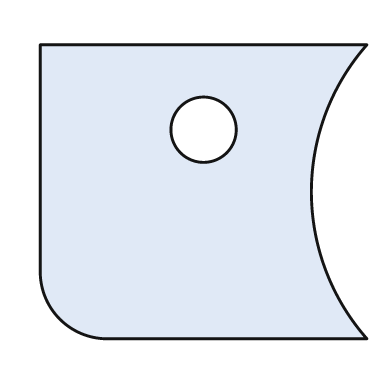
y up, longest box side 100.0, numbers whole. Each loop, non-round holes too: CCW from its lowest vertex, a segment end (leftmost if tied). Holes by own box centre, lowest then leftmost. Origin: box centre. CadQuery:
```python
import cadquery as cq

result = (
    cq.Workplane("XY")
    .moveTo(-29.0, -45.0)
    .lineTo(50.0, -45.0)
    .threePointArc((33.0, 0.0), (50.0, 45.0))
    .lineTo(-50.0, 45.0)
    .lineTo(-50.0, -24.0)
    .threePointArc((-44.0, -39.0), (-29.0, -45.0))
    .close()
    .moveTo(0.0, 19.0)
    .circle(10.0)
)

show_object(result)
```